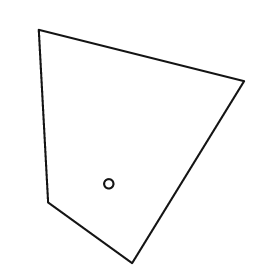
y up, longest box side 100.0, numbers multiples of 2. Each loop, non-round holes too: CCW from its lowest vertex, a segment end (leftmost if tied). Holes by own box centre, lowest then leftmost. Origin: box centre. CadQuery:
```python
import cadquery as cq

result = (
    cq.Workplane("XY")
    .moveTo(-4.0, -50.0)
    .lineTo(44.0, 28.0)
    .lineTo(-44.0, 50.0)
    .lineTo(-40.0, -24.0)
    .close()
    .moveTo(-14.0, -16.0)
    .circle(2.0)
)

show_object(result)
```